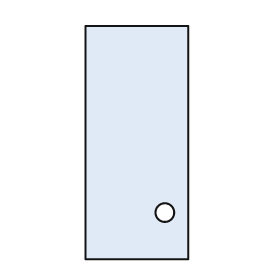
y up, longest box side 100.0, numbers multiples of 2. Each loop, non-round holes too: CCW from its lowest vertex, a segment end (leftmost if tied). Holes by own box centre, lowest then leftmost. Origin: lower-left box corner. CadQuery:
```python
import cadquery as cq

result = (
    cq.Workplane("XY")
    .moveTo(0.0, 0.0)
    .lineTo(44.0, 0.0)
    .lineTo(44.0, 100.0)
    .lineTo(0.0, 100.0)
    .close()
    .moveTo(34.0, 20.0)
    .circle(4.0)
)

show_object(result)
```